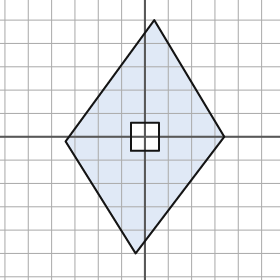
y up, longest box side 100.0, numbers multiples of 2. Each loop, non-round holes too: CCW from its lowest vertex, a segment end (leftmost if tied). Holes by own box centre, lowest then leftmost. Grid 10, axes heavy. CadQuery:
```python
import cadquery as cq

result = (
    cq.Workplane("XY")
    .moveTo(-4.0, -50.0)
    .lineTo(34.0, 0.0)
    .lineTo(4.0, 50.0)
    .lineTo(-34.0, -2.0)
    .close()
    .moveTo(-6.0, -6.0)
    .lineTo(6.0, -6.0)
    .lineTo(6.0, 6.0)
    .lineTo(-6.0, 6.0)
    .close()
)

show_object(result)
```